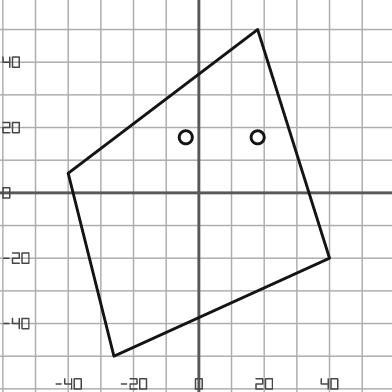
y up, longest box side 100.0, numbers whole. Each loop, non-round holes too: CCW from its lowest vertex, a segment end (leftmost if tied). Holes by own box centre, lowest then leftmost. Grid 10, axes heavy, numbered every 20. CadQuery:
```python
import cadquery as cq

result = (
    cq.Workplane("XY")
    .moveTo(-26.0, -50.0)
    .lineTo(40.0, -20.0)
    .lineTo(18.0, 50.0)
    .lineTo(-40.0, 6.0)
    .close()
    .moveTo(-4.0, 17.0)
    .circle(2.0)
    .moveTo(18.0, 17.0)
    .circle(2.0)
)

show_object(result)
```